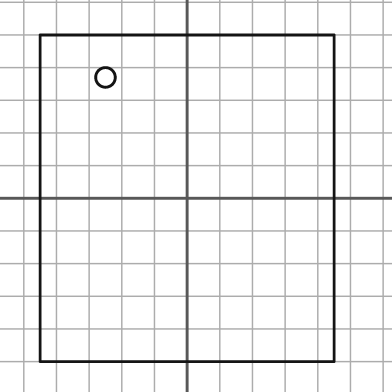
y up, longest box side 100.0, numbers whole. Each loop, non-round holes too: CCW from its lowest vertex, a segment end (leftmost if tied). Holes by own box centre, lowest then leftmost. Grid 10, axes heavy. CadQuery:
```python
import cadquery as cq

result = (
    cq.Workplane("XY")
    .moveTo(-45.0, -50.0)
    .lineTo(45.0, -50.0)
    .lineTo(45.0, 50.0)
    .lineTo(-45.0, 50.0)
    .close()
    .moveTo(-25.0, 37.0)
    .circle(3.0)
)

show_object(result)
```